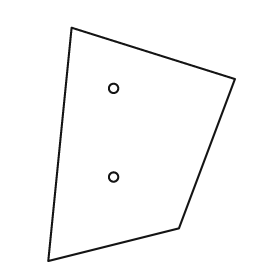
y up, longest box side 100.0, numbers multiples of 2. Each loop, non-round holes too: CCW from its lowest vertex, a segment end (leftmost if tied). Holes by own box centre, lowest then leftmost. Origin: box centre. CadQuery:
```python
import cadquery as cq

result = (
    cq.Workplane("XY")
    .moveTo(-40.0, -50.0)
    .lineTo(16.0, -36.0)
    .lineTo(40.0, 28.0)
    .lineTo(-30.0, 50.0)
    .close()
    .moveTo(-12.0, -14.0)
    .circle(2.0)
    .moveTo(-12.0, 24.0)
    .circle(2.0)
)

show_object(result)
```